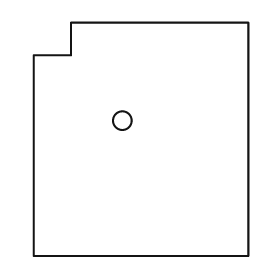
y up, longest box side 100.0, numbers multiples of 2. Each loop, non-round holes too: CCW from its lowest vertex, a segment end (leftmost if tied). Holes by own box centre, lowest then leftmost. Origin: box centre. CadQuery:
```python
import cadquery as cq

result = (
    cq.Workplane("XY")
    .moveTo(-46.0, -50.0)
    .lineTo(46.0, -50.0)
    .lineTo(46.0, 50.0)
    .lineTo(-30.0, 50.0)
    .lineTo(-30.0, 36.0)
    .lineTo(-46.0, 36.0)
    .close()
    .moveTo(-8.0, 8.0)
    .circle(4.0)
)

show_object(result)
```